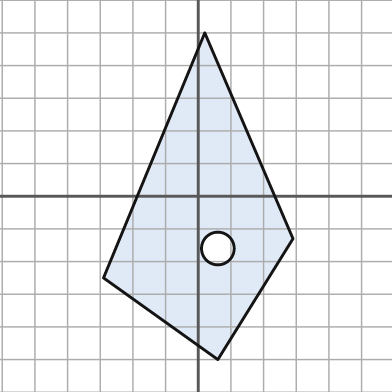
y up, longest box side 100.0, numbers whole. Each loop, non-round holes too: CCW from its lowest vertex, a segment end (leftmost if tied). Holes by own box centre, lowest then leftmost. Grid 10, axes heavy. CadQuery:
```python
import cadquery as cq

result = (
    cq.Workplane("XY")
    .moveTo(6.0, -50.0)
    .lineTo(29.0, -13.0)
    .lineTo(2.0, 50.0)
    .lineTo(-29.0, -25.0)
    .close()
    .moveTo(6.0, -16.0)
    .circle(5.0)
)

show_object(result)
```